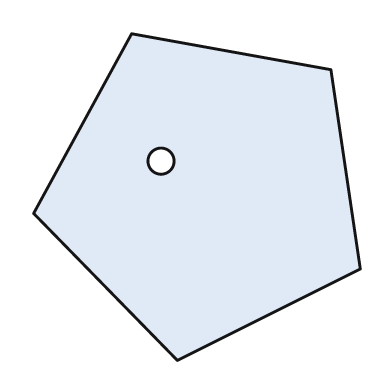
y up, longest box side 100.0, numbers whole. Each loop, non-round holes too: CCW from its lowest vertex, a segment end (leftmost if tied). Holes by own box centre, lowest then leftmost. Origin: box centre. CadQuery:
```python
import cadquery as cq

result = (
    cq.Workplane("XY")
    .moveTo(-6.0, -50.0)
    .lineTo(50.0, -22.0)
    .lineTo(41.0, 39.0)
    .lineTo(-20.0, 50.0)
    .lineTo(-50.0, -5.0)
    .close()
    .moveTo(-11.0, 11.0)
    .circle(4.0)
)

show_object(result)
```